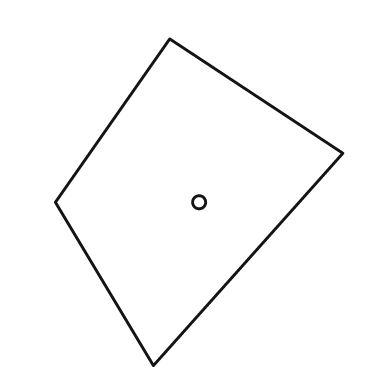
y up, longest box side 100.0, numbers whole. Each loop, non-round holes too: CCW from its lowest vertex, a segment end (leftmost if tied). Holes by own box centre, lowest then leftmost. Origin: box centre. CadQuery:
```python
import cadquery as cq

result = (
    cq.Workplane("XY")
    .moveTo(-14.0, -50.0)
    .lineTo(44.0, 15.0)
    .lineTo(-9.0, 50.0)
    .lineTo(-44.0, 0.0)
    .close()
    .moveTo(0.0, 0.0)
    .circle(2.0)
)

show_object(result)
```